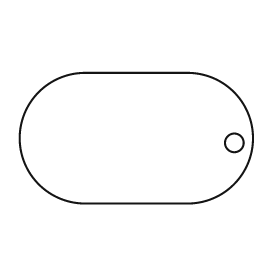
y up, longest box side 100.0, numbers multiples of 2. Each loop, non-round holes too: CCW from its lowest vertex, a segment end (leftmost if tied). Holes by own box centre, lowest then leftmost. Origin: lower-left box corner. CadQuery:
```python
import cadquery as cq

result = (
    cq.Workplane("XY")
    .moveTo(28.0, 0.0)
    .lineTo(72.0, 0.0)
    .threePointArc((100.0, 28.0), (72.0, 56.0))
    .lineTo(28.0, 56.0)
    .threePointArc((0.0, 28.0), (28.0, 0.0))
    .close()
    .moveTo(92.0, 26.0)
    .circle(4.0)
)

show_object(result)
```